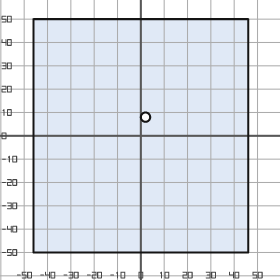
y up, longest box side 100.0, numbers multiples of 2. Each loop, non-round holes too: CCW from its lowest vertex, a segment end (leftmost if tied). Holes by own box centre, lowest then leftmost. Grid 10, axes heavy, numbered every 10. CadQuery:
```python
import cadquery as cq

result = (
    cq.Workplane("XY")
    .moveTo(-46.0, -50.0)
    .lineTo(46.0, -50.0)
    .lineTo(46.0, 50.0)
    .lineTo(-46.0, 50.0)
    .close()
    .moveTo(2.0, 8.0)
    .circle(2.0)
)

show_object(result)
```